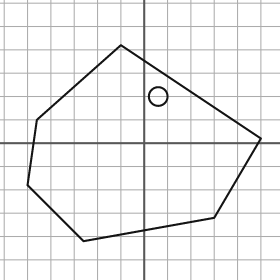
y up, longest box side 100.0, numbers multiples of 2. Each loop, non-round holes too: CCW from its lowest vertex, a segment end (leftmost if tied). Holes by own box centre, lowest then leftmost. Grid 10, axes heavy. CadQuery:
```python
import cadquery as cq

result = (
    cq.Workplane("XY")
    .moveTo(-26.0, -42.0)
    .lineTo(30.0, -32.0)
    .lineTo(50.0, 2.0)
    .lineTo(-10.0, 42.0)
    .lineTo(-46.0, 10.0)
    .lineTo(-50.0, -18.0)
    .close()
    .moveTo(6.0, 20.0)
    .circle(4.0)
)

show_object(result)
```